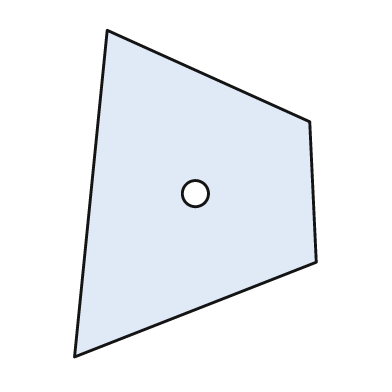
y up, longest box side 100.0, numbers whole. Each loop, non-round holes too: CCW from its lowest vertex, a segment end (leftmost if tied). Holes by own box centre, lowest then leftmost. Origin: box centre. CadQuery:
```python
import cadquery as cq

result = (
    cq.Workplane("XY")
    .moveTo(-37.0, -50.0)
    .lineTo(37.0, -21.0)
    .lineTo(35.0, 22.0)
    .lineTo(-27.0, 50.0)
    .close()
    .moveTo(0.0, 0.0)
    .circle(4.0)
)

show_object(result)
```